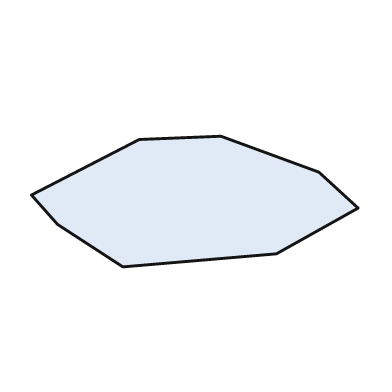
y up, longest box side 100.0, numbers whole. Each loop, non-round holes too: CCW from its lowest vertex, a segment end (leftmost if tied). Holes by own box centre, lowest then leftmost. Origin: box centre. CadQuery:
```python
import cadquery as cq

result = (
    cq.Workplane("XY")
    .moveTo(-22.0, -20.0)
    .lineTo(25.0, -16.0)
    .lineTo(50.0, -2.0)
    .lineTo(38.0, 9.0)
    .lineTo(8.0, 20.0)
    .lineTo(-17.0, 19.0)
    .lineTo(-50.0, 2.0)
    .lineTo(-42.0, -7.0)
    .close()
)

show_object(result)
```